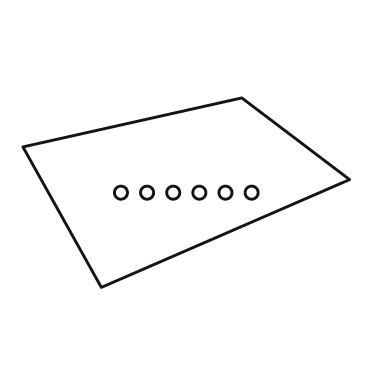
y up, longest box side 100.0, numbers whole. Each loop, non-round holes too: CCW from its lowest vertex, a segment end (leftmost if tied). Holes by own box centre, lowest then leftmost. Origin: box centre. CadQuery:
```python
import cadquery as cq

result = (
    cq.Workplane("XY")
    .moveTo(-26.0, -29.0)
    .lineTo(50.0, 4.0)
    .lineTo(17.0, 29.0)
    .lineTo(-50.0, 14.0)
    .close()
    .moveTo(-20.0, 0.0)
    .circle(2.0)
    .moveTo(-12.0, 0.0)
    .circle(2.0)
    .moveTo(-4.0, 0.0)
    .circle(2.0)
    .moveTo(4.0, 0.0)
    .circle(2.0)
    .moveTo(12.0, 0.0)
    .circle(2.0)
    .moveTo(20.0, 0.0)
    .circle(2.0)
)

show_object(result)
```